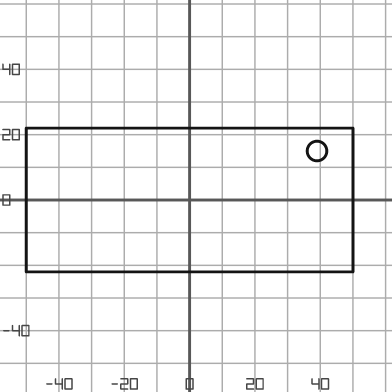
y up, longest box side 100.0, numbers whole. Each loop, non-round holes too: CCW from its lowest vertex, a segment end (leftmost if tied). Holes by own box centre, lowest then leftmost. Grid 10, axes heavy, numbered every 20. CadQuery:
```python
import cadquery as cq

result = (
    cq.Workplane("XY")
    .moveTo(-50.0, -22.0)
    .lineTo(50.0, -22.0)
    .lineTo(50.0, 22.0)
    .lineTo(-50.0, 22.0)
    .close()
    .moveTo(39.0, 15.0)
    .circle(3.0)
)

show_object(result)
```